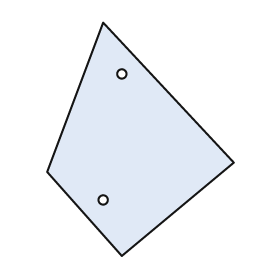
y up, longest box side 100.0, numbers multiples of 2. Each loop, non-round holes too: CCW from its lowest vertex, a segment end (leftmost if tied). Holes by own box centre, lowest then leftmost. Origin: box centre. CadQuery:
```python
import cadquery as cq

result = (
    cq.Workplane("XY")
    .moveTo(-8.0, -50.0)
    .lineTo(40.0, -10.0)
    .lineTo(-16.0, 50.0)
    .lineTo(-40.0, -14.0)
    .close()
    .moveTo(-16.0, -26.0)
    .circle(2.0)
    .moveTo(-8.0, 28.0)
    .circle(2.0)
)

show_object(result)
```